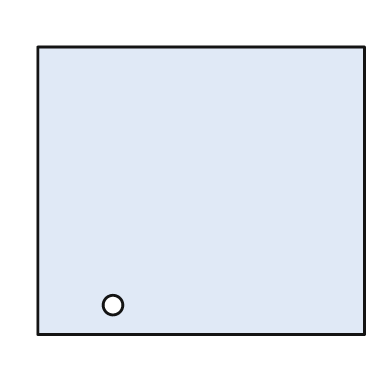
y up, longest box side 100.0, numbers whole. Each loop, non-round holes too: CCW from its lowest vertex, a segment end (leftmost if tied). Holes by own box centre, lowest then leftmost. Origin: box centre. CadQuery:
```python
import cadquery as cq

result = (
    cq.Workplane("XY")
    .moveTo(-50.0, -44.0)
    .lineTo(50.0, -44.0)
    .lineTo(50.0, 44.0)
    .lineTo(-50.0, 44.0)
    .close()
    .moveTo(-27.0, -35.0)
    .circle(3.0)
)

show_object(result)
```